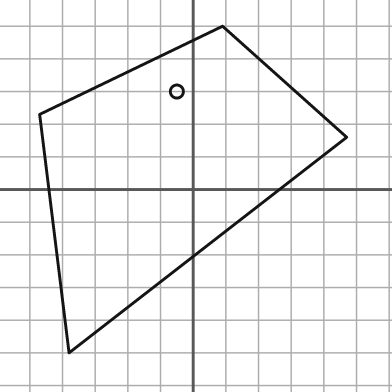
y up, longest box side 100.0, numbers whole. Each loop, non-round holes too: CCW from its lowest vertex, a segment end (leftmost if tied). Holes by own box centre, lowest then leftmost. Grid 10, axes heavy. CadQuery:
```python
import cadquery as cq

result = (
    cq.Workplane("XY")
    .moveTo(-38.0, -50.0)
    .lineTo(47.0, 16.0)
    .lineTo(9.0, 50.0)
    .lineTo(-47.0, 23.0)
    .close()
    .moveTo(-5.0, 30.0)
    .circle(2.0)
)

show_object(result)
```